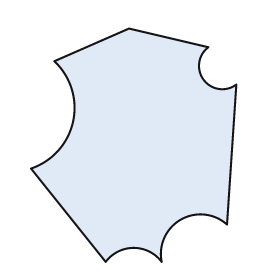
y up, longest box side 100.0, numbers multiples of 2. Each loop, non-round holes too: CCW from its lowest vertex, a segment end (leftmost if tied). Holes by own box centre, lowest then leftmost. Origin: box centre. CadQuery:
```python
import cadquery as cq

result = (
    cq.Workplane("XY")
    .moveTo(-12.0, -50.0)
    .threePointArc((0.0, -44.0), (12.0, -50.0))
    .threePointArc((20.0, -32.0), (40.0, -34.0))
    .lineTo(44.0, 26.0)
    .threePointArc((30.0, 28.0), (32.0, 42.0))
    .lineTo(-2.0, 50.0)
    .lineTo(-34.0, 36.0)
    .threePointArc((-26.0, 10.0), (-44.0, -10.0))
    .close()
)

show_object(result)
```